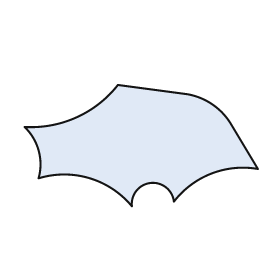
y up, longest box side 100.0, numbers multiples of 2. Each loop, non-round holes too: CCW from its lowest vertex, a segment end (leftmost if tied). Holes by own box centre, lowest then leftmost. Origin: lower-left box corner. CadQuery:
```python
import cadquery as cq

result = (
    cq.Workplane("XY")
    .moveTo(46.0, 0.0)
    .threePointArc((54.0, 10.0), (64.0, 2.0))
    .threePointArc((80.0, 14.0), (100.0, 16.0))
    .lineTo(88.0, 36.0)
    .threePointArc((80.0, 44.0), (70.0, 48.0))
    .lineTo(40.0, 52.0)
    .threePointArc((22.0, 38.0), (0.0, 34.0))
    .threePointArc((6.0, 24.0), (6.0, 12.0))
    .threePointArc((28.0, 12.0), (46.0, 0.0))
    .close()
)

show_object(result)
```